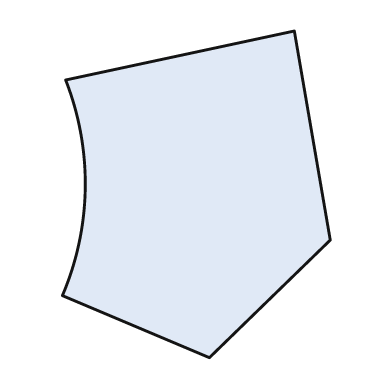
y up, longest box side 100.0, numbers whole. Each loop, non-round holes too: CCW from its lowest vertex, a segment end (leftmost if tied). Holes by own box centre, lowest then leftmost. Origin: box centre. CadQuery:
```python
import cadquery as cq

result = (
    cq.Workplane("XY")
    .moveTo(4.0, -50.0)
    .lineTo(41.0, -14.0)
    .lineTo(30.0, 50.0)
    .lineTo(-40.0, 35.0)
    .threePointArc((-34.0, 2.0), (-41.0, -31.0))
    .close()
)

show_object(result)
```